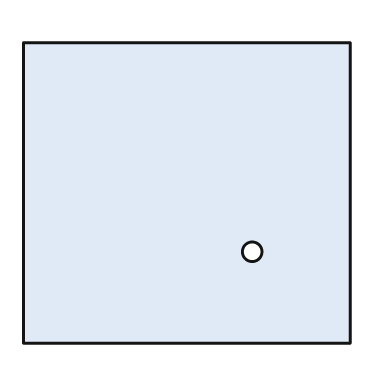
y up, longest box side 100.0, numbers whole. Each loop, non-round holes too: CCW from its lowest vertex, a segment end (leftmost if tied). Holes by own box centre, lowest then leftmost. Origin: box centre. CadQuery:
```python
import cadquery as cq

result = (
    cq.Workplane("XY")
    .moveTo(-50.0, -46.0)
    .lineTo(50.0, -46.0)
    .lineTo(50.0, 46.0)
    .lineTo(-50.0, 46.0)
    .close()
    .moveTo(20.0, -18.0)
    .circle(3.0)
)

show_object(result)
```